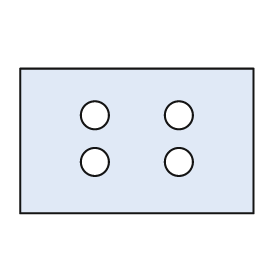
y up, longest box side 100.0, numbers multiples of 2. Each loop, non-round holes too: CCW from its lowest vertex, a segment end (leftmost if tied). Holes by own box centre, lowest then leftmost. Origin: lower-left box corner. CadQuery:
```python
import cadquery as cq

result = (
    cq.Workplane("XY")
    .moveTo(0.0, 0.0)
    .lineTo(100.0, 0.0)
    .lineTo(100.0, 62.0)
    .lineTo(0.0, 62.0)
    .close()
    .moveTo(32.0, 22.0)
    .circle(6.0)
    .moveTo(68.0, 22.0)
    .circle(6.0)
    .moveTo(32.0, 42.0)
    .circle(6.0)
    .moveTo(68.0, 42.0)
    .circle(6.0)
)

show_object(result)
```